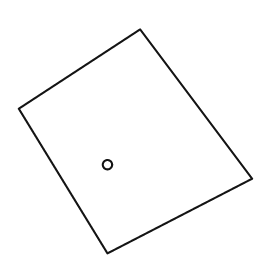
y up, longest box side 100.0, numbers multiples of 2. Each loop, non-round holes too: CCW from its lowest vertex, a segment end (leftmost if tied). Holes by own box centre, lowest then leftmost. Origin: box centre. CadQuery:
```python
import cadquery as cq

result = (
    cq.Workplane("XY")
    .moveTo(-12.0, -48.0)
    .lineTo(50.0, -16.0)
    .lineTo(2.0, 48.0)
    .lineTo(-50.0, 14.0)
    .close()
    .moveTo(-12.0, -10.0)
    .circle(2.0)
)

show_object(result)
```